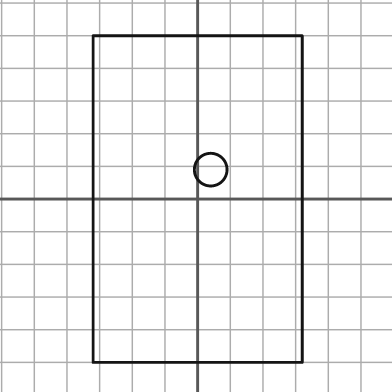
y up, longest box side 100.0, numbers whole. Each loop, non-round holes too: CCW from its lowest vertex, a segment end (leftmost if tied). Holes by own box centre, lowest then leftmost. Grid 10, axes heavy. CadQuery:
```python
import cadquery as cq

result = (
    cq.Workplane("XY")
    .moveTo(-32.0, -50.0)
    .lineTo(32.0, -50.0)
    .lineTo(32.0, 50.0)
    .lineTo(-32.0, 50.0)
    .close()
    .moveTo(4.0, 9.0)
    .circle(5.0)
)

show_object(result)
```